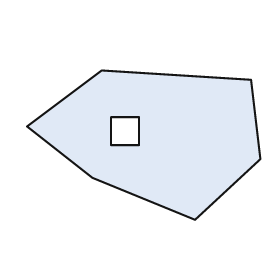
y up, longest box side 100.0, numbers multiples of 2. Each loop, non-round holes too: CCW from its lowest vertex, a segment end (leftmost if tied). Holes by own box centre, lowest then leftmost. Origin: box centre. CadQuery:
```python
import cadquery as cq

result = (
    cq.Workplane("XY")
    .moveTo(22.0, -32.0)
    .lineTo(50.0, -6.0)
    .lineTo(46.0, 28.0)
    .lineTo(-18.0, 32.0)
    .lineTo(-50.0, 8.0)
    .lineTo(-22.0, -14.0)
    .close()
    .moveTo(-14.0, 0.0)
    .lineTo(-2.0, 0.0)
    .lineTo(-2.0, 12.0)
    .lineTo(-14.0, 12.0)
    .close()
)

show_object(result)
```